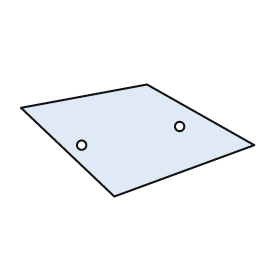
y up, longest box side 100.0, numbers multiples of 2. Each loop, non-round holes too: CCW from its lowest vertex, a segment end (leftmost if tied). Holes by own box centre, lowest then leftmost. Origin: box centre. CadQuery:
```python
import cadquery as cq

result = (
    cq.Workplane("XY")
    .moveTo(-10.0, -24.0)
    .lineTo(50.0, -2.0)
    .lineTo(4.0, 24.0)
    .lineTo(-50.0, 14.0)
    .close()
    .moveTo(-24.0, -2.0)
    .circle(2.0)
    .moveTo(18.0, 6.0)
    .circle(2.0)
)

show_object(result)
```